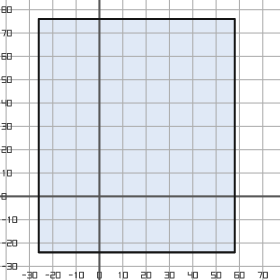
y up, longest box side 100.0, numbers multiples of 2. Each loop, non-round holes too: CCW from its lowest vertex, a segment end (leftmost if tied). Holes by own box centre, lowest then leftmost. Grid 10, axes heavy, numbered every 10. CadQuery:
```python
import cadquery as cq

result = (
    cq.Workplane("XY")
    .moveTo(-26.0, -24.0)
    .lineTo(58.0, -24.0)
    .lineTo(58.0, 76.0)
    .lineTo(-26.0, 76.0)
    .close()
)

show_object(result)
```